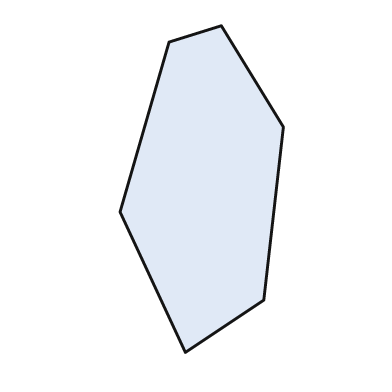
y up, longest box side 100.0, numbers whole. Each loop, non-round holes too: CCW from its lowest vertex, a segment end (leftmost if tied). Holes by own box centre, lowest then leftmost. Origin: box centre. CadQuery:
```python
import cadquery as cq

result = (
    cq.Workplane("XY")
    .moveTo(-5.0, -50.0)
    .lineTo(19.0, -34.0)
    .lineTo(25.0, 19.0)
    .lineTo(6.0, 50.0)
    .lineTo(-10.0, 45.0)
    .lineTo(-25.0, -7.0)
    .close()
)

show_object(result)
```